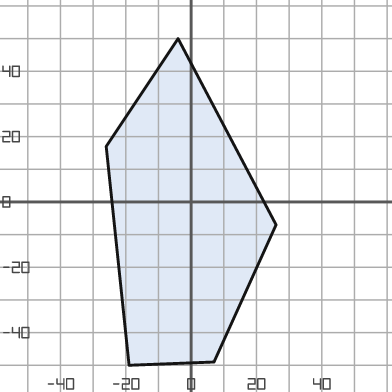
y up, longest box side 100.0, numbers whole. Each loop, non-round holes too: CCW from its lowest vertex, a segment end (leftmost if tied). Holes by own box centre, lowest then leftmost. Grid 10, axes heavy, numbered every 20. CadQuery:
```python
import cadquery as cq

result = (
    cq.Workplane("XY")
    .moveTo(-19.0, -50.0)
    .lineTo(7.0, -49.0)
    .lineTo(26.0, -7.0)
    .lineTo(-4.0, 50.0)
    .lineTo(-26.0, 17.0)
    .close()
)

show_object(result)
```